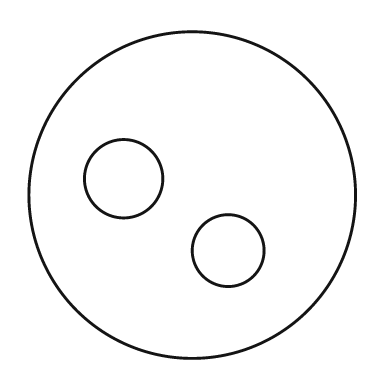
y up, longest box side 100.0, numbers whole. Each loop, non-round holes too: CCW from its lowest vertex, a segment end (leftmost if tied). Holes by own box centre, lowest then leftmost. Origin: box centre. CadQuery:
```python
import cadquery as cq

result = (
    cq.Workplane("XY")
    .moveTo(0.0, 0.0)
    .circle(50.0)
    .moveTo(11.0, -17.0)
    .circle(11.0)
    .moveTo(-21.0, 5.0)
    .circle(12.0)
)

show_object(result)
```